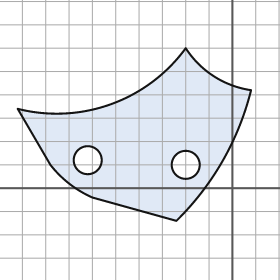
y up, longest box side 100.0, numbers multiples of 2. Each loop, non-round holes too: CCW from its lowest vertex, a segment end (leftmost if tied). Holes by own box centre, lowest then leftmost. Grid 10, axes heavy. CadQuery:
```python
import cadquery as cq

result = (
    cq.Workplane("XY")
    .moveTo(-24.0, -14.0)
    .threePointArc((-4.0, 12.0), (8.0, 42.0))
    .threePointArc((-8.0, 48.0), (-20.0, 60.0))
    .threePointArc((-52.0, 36.0), (-92.0, 34.0))
    .lineTo(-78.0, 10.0)
    .threePointArc((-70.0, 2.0), (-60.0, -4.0))
    .close()
    .moveTo(-20.0, 10.0)
    .circle(6.0)
    .moveTo(-62.0, 12.0)
    .circle(6.0)
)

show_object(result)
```